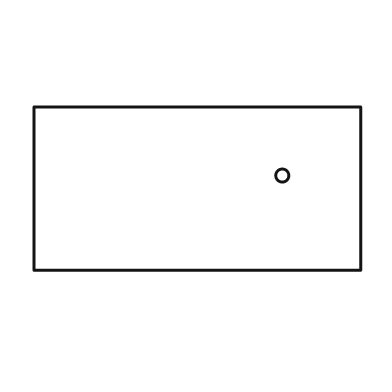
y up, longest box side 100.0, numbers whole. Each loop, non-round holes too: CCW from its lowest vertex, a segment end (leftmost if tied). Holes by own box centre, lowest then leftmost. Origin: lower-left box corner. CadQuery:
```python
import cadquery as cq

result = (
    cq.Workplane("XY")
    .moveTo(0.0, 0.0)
    .lineTo(100.0, 0.0)
    .lineTo(100.0, 50.0)
    .lineTo(0.0, 50.0)
    .close()
    .moveTo(76.0, 29.0)
    .circle(2.0)
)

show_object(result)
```